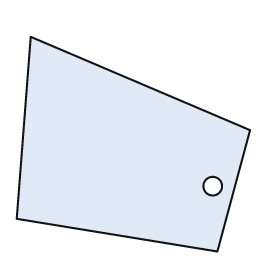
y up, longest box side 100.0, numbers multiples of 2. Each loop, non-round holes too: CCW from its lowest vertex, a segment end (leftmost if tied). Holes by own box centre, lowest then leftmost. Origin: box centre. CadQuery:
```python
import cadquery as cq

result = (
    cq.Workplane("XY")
    .moveTo(36.0, -46.0)
    .lineTo(50.0, 6.0)
    .lineTo(-44.0, 46.0)
    .lineTo(-50.0, -32.0)
    .close()
    .moveTo(34.0, -18.0)
    .circle(4.0)
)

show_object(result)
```